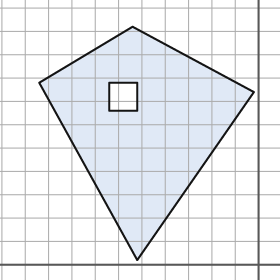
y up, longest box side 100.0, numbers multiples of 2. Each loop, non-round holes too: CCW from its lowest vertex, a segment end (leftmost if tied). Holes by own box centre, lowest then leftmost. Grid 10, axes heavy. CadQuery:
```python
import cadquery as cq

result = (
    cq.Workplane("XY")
    .moveTo(-52.0, 2.0)
    .lineTo(-2.0, 74.0)
    .lineTo(-54.0, 102.0)
    .lineTo(-94.0, 78.0)
    .close()
    .moveTo(-64.0, 66.0)
    .lineTo(-52.0, 66.0)
    .lineTo(-52.0, 78.0)
    .lineTo(-64.0, 78.0)
    .close()
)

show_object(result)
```